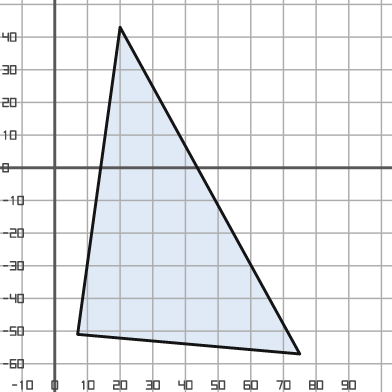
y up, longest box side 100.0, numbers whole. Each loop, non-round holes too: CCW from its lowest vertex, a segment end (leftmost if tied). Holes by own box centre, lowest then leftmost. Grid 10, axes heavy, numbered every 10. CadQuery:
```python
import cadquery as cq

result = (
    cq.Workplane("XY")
    .moveTo(75.0, -57.0)
    .lineTo(20.0, 43.0)
    .lineTo(7.0, -51.0)
    .close()
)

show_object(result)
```